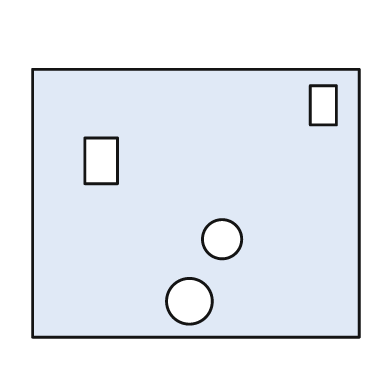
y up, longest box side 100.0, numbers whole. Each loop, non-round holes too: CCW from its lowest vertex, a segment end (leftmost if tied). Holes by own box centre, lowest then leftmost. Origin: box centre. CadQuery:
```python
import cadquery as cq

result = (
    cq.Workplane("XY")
    .moveTo(-50.0, -41.0)
    .lineTo(50.0, -41.0)
    .lineTo(50.0, 41.0)
    .lineTo(-50.0, 41.0)
    .close()
    .moveTo(-2.0, -30.0)
    .circle(7.0)
    .moveTo(8.0, -11.0)
    .circle(6.0)
    .moveTo(-34.0, 6.0)
    .lineTo(-24.0, 6.0)
    .lineTo(-24.0, 20.0)
    .lineTo(-34.0, 20.0)
    .close()
    .moveTo(35.0, 24.0)
    .lineTo(43.0, 24.0)
    .lineTo(43.0, 36.0)
    .lineTo(35.0, 36.0)
    .close()
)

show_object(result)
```